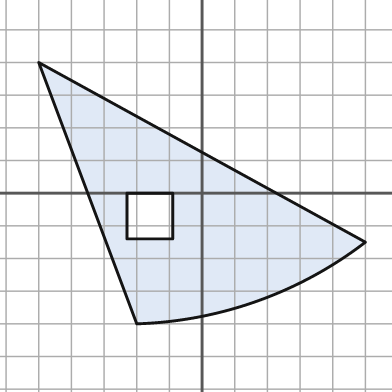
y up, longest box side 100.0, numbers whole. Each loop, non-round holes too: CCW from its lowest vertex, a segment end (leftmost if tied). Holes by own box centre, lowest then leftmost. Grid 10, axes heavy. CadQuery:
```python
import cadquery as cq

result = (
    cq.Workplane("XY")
    .moveTo(-20.0, -40.0)
    .threePointArc((17.0, -33.0), (50.0, -15.0))
    .lineTo(-50.0, 40.0)
    .close()
    .moveTo(-23.0, -14.0)
    .lineTo(-9.0, -14.0)
    .lineTo(-9.0, 0.0)
    .lineTo(-23.0, 0.0)
    .close()
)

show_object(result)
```